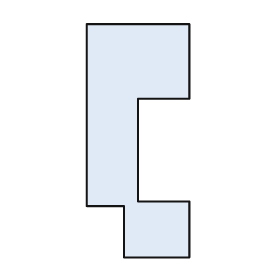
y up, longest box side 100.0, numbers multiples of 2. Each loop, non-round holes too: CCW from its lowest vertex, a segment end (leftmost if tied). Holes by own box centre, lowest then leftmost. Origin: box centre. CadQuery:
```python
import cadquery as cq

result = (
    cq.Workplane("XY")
    .moveTo(-6.0, -50.0)
    .lineTo(22.0, -50.0)
    .lineTo(22.0, -26.0)
    .lineTo(0.0, -26.0)
    .lineTo(0.0, 18.0)
    .lineTo(22.0, 18.0)
    .lineTo(22.0, 50.0)
    .lineTo(-22.0, 50.0)
    .lineTo(-22.0, -28.0)
    .lineTo(-6.0, -28.0)
    .close()
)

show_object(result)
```